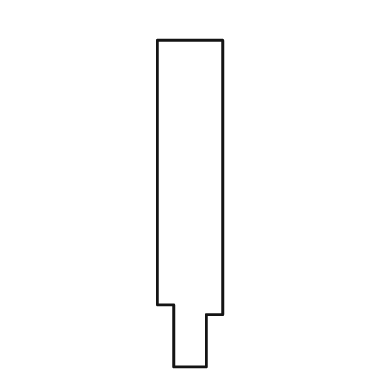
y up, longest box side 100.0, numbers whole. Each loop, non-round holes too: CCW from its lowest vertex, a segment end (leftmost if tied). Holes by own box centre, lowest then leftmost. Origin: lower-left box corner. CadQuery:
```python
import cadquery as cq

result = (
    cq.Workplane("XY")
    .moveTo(5.0, 0.0)
    .lineTo(15.0, 0.0)
    .lineTo(15.0, 16.0)
    .lineTo(20.0, 16.0)
    .lineTo(20.0, 100.0)
    .lineTo(0.0, 100.0)
    .lineTo(0.0, 19.0)
    .lineTo(5.0, 19.0)
    .close()
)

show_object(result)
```